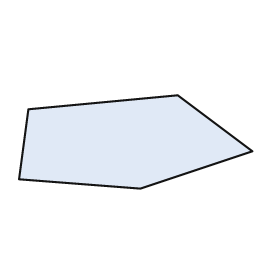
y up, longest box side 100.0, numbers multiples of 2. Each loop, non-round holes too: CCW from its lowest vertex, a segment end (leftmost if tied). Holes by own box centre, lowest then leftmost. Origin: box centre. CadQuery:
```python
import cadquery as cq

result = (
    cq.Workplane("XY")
    .moveTo(2.0, -20.0)
    .lineTo(50.0, -4.0)
    .lineTo(18.0, 20.0)
    .lineTo(-46.0, 14.0)
    .lineTo(-50.0, -16.0)
    .close()
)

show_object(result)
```